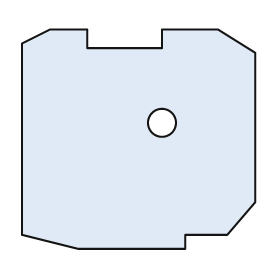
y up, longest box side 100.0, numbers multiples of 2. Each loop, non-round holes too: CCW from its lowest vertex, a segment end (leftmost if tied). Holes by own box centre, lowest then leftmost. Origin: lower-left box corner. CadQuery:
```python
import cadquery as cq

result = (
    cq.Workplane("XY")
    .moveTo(24.0, 0.0)
    .lineTo(70.0, 0.0)
    .lineTo(70.0, 6.0)
    .lineTo(88.0, 6.0)
    .lineTo(100.0, 20.0)
    .lineTo(100.0, 84.0)
    .lineTo(84.0, 94.0)
    .lineTo(60.0, 94.0)
    .lineTo(60.0, 86.0)
    .lineTo(28.0, 86.0)
    .lineTo(28.0, 94.0)
    .lineTo(12.0, 94.0)
    .lineTo(0.0, 88.0)
    .lineTo(0.0, 6.0)
    .close()
    .moveTo(60.0, 54.0)
    .circle(6.0)
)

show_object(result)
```